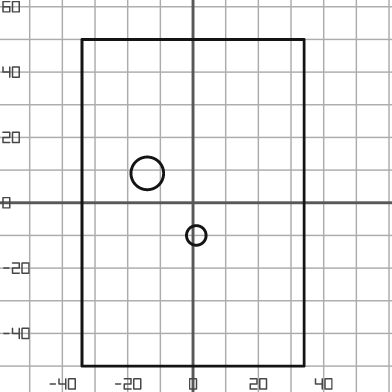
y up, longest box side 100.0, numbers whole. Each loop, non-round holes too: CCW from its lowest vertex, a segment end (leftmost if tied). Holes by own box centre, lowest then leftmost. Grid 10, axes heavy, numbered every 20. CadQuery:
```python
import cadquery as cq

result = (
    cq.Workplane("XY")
    .moveTo(-34.0, -50.0)
    .lineTo(34.0, -50.0)
    .lineTo(34.0, 50.0)
    .lineTo(-34.0, 50.0)
    .close()
    .moveTo(1.0, -10.0)
    .circle(3.0)
    .moveTo(-14.0, 9.0)
    .circle(5.0)
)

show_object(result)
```